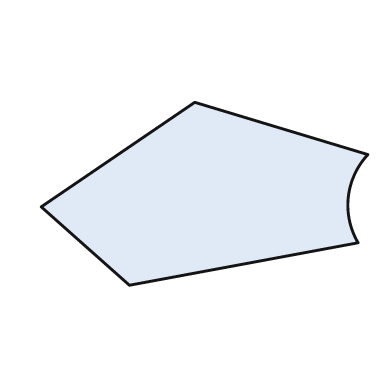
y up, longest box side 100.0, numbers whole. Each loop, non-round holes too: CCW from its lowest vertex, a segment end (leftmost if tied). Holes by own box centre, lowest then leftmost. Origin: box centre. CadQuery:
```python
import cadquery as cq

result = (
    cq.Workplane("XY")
    .moveTo(-23.0, -28.0)
    .lineTo(47.0, -15.0)
    .threePointArc((44.0, -1.0), (50.0, 12.0))
    .lineTo(-3.0, 28.0)
    .lineTo(-50.0, -4.0)
    .close()
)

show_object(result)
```